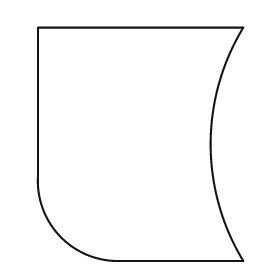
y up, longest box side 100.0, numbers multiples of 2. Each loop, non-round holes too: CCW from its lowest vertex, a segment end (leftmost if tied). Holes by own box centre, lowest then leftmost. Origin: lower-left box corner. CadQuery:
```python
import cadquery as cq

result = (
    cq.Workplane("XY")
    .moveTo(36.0, 0.0)
    .lineTo(88.0, 0.0)
    .threePointArc((74.0, 50.0), (88.0, 100.0))
    .lineTo(0.0, 100.0)
    .lineTo(0.0, 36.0)
    .threePointArc((10.0, 10.0), (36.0, 0.0))
    .close()
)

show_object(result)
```